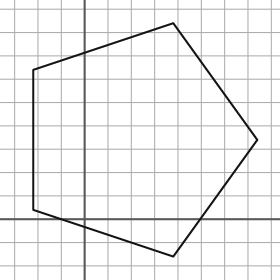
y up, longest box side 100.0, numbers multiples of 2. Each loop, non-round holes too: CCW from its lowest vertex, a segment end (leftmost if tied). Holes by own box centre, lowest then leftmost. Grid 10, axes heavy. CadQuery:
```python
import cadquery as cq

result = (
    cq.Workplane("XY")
    .moveTo(38.0, -16.0)
    .lineTo(74.0, 34.0)
    .lineTo(38.0, 84.0)
    .lineTo(-22.0, 64.0)
    .lineTo(-22.0, 4.0)
    .close()
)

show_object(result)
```